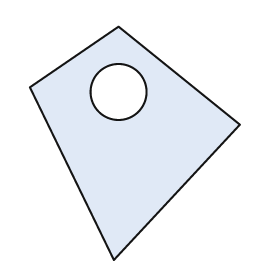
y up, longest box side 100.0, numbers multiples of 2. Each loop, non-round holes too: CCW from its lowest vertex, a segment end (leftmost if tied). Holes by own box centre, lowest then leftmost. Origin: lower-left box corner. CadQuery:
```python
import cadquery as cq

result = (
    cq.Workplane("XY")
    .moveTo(36.0, 0.0)
    .lineTo(90.0, 58.0)
    .lineTo(38.0, 100.0)
    .lineTo(0.0, 74.0)
    .close()
    .moveTo(38.0, 72.0)
    .circle(12.0)
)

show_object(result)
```